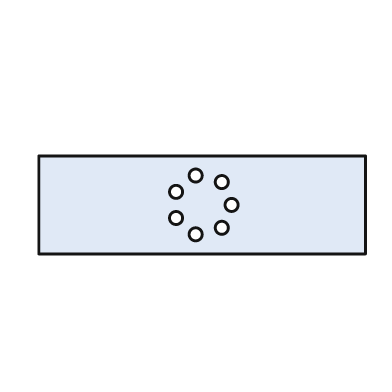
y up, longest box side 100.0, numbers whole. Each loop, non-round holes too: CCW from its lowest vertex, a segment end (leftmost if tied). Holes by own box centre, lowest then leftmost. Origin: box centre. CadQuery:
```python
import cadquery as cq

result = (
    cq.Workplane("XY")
    .moveTo(-50.0, -15.0)
    .lineTo(50.0, -15.0)
    .lineTo(50.0, 15.0)
    .lineTo(-50.0, 15.0)
    .close()
    .moveTo(-2.0, -9.0)
    .circle(2.0)
    .moveTo(6.0, -7.0)
    .circle(2.0)
    .moveTo(-8.0, -4.0)
    .circle(2.0)
    .moveTo(9.0, 0.0)
    .circle(2.0)
    .moveTo(-8.0, 4.0)
    .circle(2.0)
    .moveTo(6.0, 7.0)
    .circle(2.0)
    .moveTo(-2.0, 9.0)
    .circle(2.0)
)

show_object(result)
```